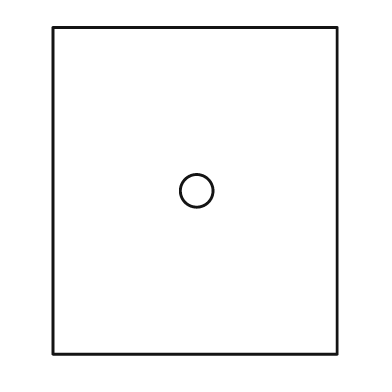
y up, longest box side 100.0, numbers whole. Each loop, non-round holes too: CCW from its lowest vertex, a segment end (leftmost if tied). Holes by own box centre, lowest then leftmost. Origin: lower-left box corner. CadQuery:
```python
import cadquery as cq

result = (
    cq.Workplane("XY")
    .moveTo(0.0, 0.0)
    .lineTo(87.0, 0.0)
    .lineTo(87.0, 100.0)
    .lineTo(0.0, 100.0)
    .close()
    .moveTo(44.0, 50.0)
    .circle(5.0)
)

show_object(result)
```